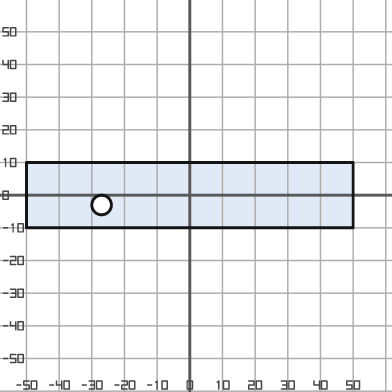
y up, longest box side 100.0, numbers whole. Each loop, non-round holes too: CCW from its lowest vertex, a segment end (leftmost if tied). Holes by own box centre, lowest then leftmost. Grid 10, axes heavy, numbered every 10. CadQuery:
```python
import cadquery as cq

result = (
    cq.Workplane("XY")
    .moveTo(-50.0, -10.0)
    .lineTo(50.0, -10.0)
    .lineTo(50.0, 10.0)
    .lineTo(-50.0, 10.0)
    .close()
    .moveTo(-27.0, -3.0)
    .circle(3.0)
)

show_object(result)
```